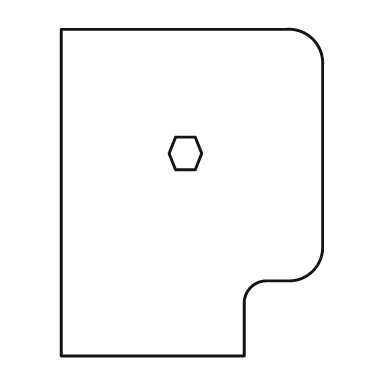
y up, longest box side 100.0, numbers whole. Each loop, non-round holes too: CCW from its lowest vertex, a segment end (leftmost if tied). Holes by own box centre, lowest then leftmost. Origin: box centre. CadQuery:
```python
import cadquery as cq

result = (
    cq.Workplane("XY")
    .moveTo(-40.0, -50.0)
    .lineTo(16.0, -50.0)
    .lineTo(16.0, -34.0)
    .threePointArc((18.0, -29.0), (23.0, -27.0))
    .lineTo(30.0, -27.0)
    .threePointArc((37.0, -24.0), (40.0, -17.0))
    .lineTo(40.0, 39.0)
    .threePointArc((37.0, 47.0), (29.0, 50.0))
    .lineTo(-40.0, 50.0)
    .close()
    .moveTo(-5.0, 7.0)
    .lineTo(1.0, 7.0)
    .lineTo(3.0, 12.0)
    .lineTo(1.0, 17.0)
    .lineTo(-5.0, 17.0)
    .lineTo(-7.0, 12.0)
    .close()
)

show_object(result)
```